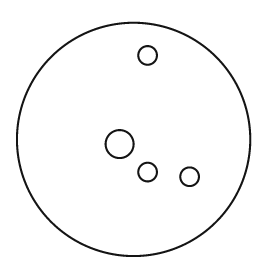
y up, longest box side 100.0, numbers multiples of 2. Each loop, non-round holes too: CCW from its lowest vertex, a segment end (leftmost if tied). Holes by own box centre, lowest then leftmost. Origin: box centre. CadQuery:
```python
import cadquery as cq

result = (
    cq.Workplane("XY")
    .moveTo(0.0, 0.0)
    .circle(50.0)
    .moveTo(24.0, -16.0)
    .circle(4.0)
    .moveTo(6.0, -14.0)
    .circle(4.0)
    .moveTo(-6.0, -2.0)
    .circle(6.0)
    .moveTo(6.0, 36.0)
    .circle(4.0)
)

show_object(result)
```